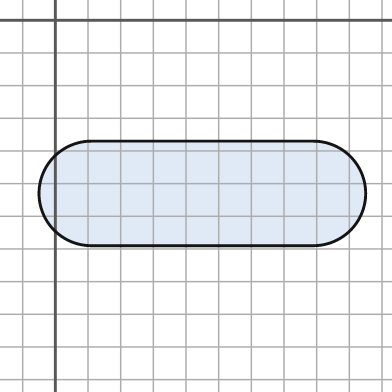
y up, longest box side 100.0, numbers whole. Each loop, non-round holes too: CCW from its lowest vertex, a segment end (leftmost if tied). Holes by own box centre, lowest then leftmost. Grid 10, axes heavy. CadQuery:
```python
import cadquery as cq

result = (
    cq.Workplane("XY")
    .moveTo(11.0, -69.0)
    .lineTo(79.0, -69.0)
    .threePointArc((95.0, -53.0), (79.0, -37.0))
    .lineTo(11.0, -37.0)
    .threePointArc((-5.0, -53.0), (11.0, -69.0))
    .close()
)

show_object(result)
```